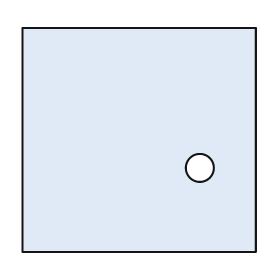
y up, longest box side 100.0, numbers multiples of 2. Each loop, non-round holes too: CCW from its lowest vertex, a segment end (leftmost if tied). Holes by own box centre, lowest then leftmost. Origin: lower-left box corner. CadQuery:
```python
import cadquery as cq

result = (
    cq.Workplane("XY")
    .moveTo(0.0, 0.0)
    .lineTo(100.0, 0.0)
    .lineTo(100.0, 96.0)
    .lineTo(0.0, 96.0)
    .close()
    .moveTo(76.0, 36.0)
    .circle(6.0)
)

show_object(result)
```